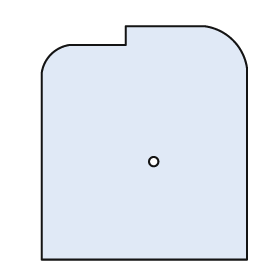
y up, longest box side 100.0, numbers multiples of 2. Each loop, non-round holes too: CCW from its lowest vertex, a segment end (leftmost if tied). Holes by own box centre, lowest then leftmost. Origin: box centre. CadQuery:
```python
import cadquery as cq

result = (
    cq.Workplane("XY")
    .moveTo(-44.0, -50.0)
    .lineTo(44.0, -50.0)
    .lineTo(44.0, 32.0)
    .threePointArc((38.0, 44.0), (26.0, 50.0))
    .lineTo(-8.0, 50.0)
    .lineTo(-8.0, 42.0)
    .lineTo(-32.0, 42.0)
    .threePointArc((-40.0, 38.0), (-44.0, 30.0))
    .close()
    .moveTo(4.0, -8.0)
    .circle(2.0)
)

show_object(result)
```